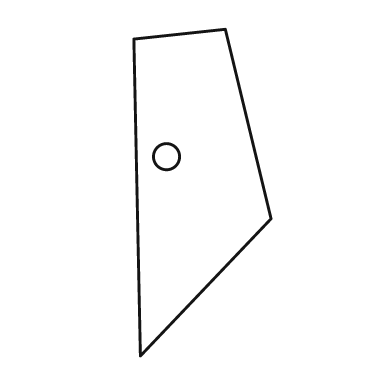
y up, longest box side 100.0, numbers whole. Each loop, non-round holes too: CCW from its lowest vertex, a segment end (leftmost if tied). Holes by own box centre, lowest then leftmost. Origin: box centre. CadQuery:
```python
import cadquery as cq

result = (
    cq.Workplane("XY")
    .moveTo(-19.0, -50.0)
    .lineTo(21.0, -8.0)
    .lineTo(7.0, 50.0)
    .lineTo(-21.0, 47.0)
    .close()
    .moveTo(-11.0, 11.0)
    .circle(4.0)
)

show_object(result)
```